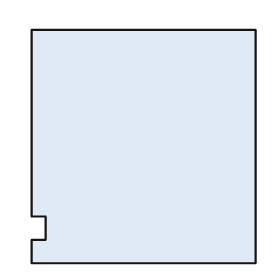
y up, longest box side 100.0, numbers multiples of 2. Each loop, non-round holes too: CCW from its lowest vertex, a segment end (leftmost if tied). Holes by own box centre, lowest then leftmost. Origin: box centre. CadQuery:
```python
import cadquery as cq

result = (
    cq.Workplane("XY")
    .moveTo(-48.0, -50.0)
    .lineTo(48.0, -50.0)
    .lineTo(48.0, 50.0)
    .lineTo(-48.0, 50.0)
    .lineTo(-48.0, -30.0)
    .lineTo(-42.0, -30.0)
    .lineTo(-42.0, -40.0)
    .lineTo(-48.0, -40.0)
    .close()
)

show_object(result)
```